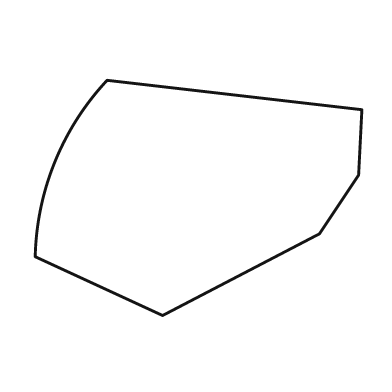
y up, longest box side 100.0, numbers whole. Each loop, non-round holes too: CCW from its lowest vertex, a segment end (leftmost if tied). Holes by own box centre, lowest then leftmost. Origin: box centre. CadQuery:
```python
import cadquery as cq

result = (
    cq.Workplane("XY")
    .moveTo(-11.0, -36.0)
    .lineTo(37.0, -11.0)
    .lineTo(49.0, 7.0)
    .lineTo(50.0, 27.0)
    .lineTo(-28.0, 36.0)
    .threePointArc((-44.0, 11.0), (-50.0, -18.0))
    .close()
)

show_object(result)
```